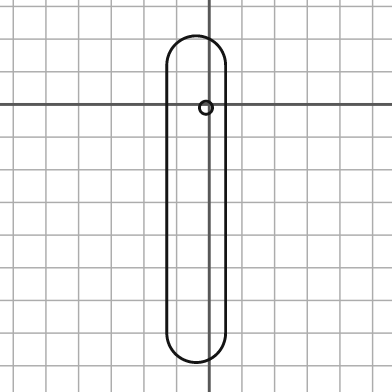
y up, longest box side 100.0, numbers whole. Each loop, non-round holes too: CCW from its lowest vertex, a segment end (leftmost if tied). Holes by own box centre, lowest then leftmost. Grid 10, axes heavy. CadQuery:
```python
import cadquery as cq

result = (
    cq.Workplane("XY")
    .moveTo(-13.0, -70.0)
    .threePointArc((-4.0, -79.0), (5.0, -70.0))
    .lineTo(5.0, 12.0)
    .threePointArc((-4.0, 21.0), (-13.0, 12.0))
    .close()
    .moveTo(-1.0, -1.0)
    .circle(2.0)
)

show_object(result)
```